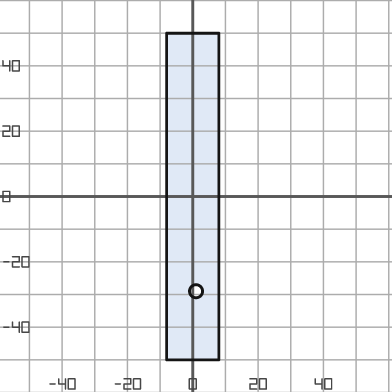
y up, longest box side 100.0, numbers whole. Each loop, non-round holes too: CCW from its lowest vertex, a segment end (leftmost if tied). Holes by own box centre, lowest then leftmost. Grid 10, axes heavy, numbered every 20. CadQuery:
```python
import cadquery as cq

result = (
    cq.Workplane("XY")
    .moveTo(-8.0, -50.0)
    .lineTo(8.0, -50.0)
    .lineTo(8.0, 50.0)
    .lineTo(-8.0, 50.0)
    .close()
    .moveTo(1.0, -29.0)
    .circle(2.0)
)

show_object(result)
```